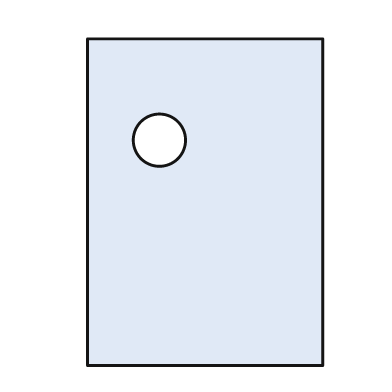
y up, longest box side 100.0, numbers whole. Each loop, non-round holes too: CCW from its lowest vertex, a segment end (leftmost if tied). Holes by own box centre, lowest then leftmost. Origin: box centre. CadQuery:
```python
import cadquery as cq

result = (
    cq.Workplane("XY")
    .moveTo(-36.0, -50.0)
    .lineTo(36.0, -50.0)
    .lineTo(36.0, 50.0)
    .lineTo(-36.0, 50.0)
    .close()
    .moveTo(-14.0, 19.0)
    .circle(8.0)
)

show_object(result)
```